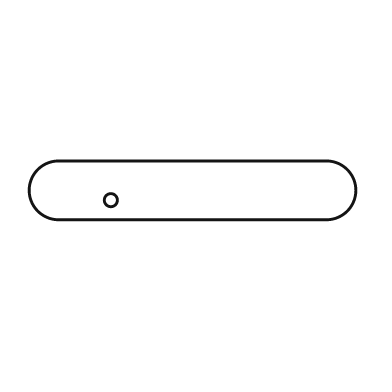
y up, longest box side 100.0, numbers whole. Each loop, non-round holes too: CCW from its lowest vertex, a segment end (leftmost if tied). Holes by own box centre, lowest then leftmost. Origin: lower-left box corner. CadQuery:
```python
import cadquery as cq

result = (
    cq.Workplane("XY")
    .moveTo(9.0, 0.0)
    .lineTo(91.0, 0.0)
    .threePointArc((100.0, 9.0), (91.0, 18.0))
    .lineTo(9.0, 18.0)
    .threePointArc((0.0, 9.0), (9.0, 0.0))
    .close()
    .moveTo(25.0, 6.0)
    .circle(2.0)
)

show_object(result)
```